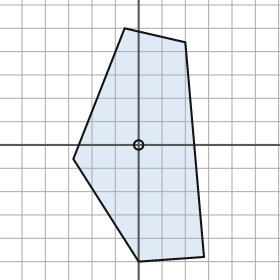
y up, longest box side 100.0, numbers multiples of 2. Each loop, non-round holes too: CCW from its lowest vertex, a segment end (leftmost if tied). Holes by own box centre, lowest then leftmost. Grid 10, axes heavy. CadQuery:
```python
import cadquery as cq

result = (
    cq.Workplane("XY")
    .moveTo(0.0, -50.0)
    .lineTo(28.0, -48.0)
    .lineTo(20.0, 44.0)
    .lineTo(-6.0, 50.0)
    .lineTo(-28.0, -6.0)
    .close()
    .moveTo(0.0, 0.0)
    .circle(2.0)
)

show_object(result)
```